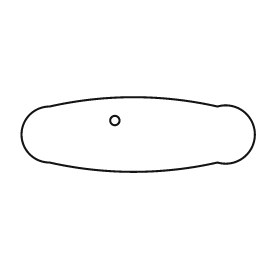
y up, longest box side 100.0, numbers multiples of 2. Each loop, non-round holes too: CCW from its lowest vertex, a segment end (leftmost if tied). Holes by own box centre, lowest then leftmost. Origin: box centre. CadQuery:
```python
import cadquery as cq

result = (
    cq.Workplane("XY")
    .moveTo(-38.0, -12.0)
    .threePointArc((-2.0, -16.0), (34.0, -12.0))
    .threePointArc((50.0, 0.0), (34.0, 12.0))
    .threePointArc((-2.0, 16.0), (-38.0, 12.0))
    .threePointArc((-50.0, 0.0), (-38.0, -12.0))
    .close()
    .moveTo(-10.0, 6.0)
    .circle(2.0)
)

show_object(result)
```